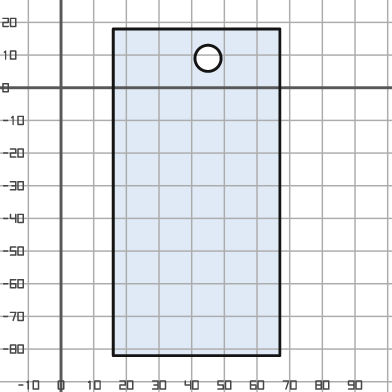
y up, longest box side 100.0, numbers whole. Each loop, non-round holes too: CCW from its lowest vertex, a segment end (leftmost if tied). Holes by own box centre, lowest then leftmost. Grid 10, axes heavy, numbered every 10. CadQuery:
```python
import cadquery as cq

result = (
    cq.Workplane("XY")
    .moveTo(16.0, -82.0)
    .lineTo(67.0, -82.0)
    .lineTo(67.0, 18.0)
    .lineTo(16.0, 18.0)
    .close()
    .moveTo(45.0, 9.0)
    .circle(4.0)
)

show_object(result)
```